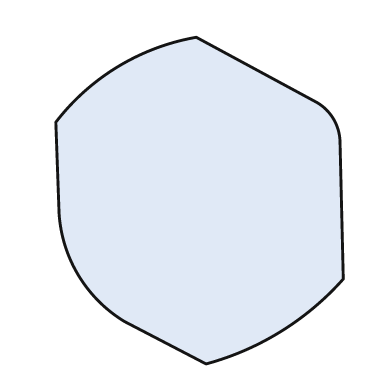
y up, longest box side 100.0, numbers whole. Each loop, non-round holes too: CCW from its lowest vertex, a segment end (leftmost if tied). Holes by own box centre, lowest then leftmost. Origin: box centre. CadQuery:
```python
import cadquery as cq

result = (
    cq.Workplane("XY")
    .moveTo(2.0, -50.0)
    .threePointArc((25.0, -40.0), (44.0, -24.0))
    .lineTo(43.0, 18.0)
    .threePointArc((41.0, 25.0), (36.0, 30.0))
    .lineTo(-1.0, 50.0)
    .threePointArc((-25.0, 41.0), (-44.0, 24.0))
    .lineTo(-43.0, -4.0)
    .threePointArc((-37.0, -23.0), (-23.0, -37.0))
    .close()
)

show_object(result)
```